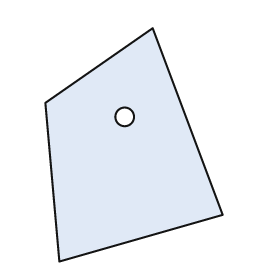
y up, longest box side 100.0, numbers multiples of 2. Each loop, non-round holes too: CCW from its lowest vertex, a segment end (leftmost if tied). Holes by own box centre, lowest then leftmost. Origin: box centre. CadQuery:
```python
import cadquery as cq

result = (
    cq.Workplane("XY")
    .moveTo(-32.0, -50.0)
    .lineTo(38.0, -30.0)
    .lineTo(8.0, 50.0)
    .lineTo(-38.0, 18.0)
    .close()
    .moveTo(-4.0, 12.0)
    .circle(4.0)
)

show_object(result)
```